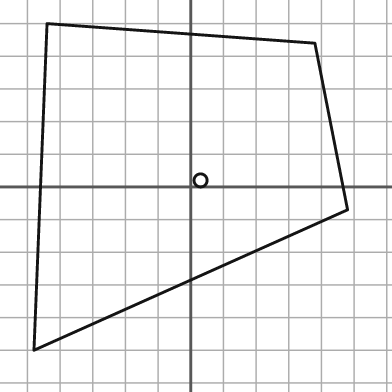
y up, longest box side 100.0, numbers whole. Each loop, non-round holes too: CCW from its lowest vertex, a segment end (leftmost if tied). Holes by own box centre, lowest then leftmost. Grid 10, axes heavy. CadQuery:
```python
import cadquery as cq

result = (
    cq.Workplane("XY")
    .moveTo(-48.0, -50.0)
    .lineTo(48.0, -7.0)
    .lineTo(38.0, 44.0)
    .lineTo(-44.0, 50.0)
    .close()
    .moveTo(3.0, 2.0)
    .circle(2.0)
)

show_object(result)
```